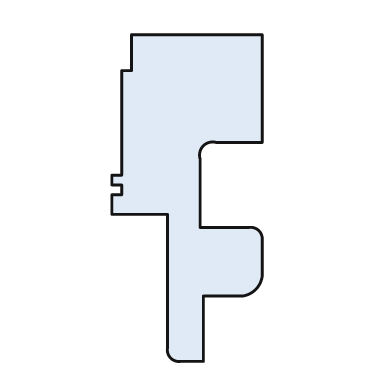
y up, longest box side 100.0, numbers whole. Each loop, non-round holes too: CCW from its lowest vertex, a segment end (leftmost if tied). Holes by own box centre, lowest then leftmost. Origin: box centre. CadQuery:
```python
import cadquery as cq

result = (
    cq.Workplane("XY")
    .moveTo(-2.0, -50.0)
    .lineTo(5.0, -50.0)
    .lineTo(5.0, -30.0)
    .lineTo(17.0, -30.0)
    .threePointArc((21.0, -28.0), (23.0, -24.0))
    .lineTo(23.0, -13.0)
    .threePointArc((22.0, -10.0), (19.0, -9.0))
    .lineTo(4.0, -9.0)
    .lineTo(4.0, 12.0)
    .threePointArc((5.0, 16.0), (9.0, 17.0))
    .lineTo(23.0, 17.0)
    .lineTo(23.0, 50.0)
    .lineTo(-17.0, 50.0)
    .lineTo(-17.0, 39.0)
    .lineTo(-20.0, 39.0)
    .lineTo(-20.0, 7.0)
    .lineTo(-23.0, 7.0)
    .lineTo(-23.0, 4.0)
    .lineTo(-20.0, 4.0)
    .lineTo(-20.0, 1.0)
    .lineTo(-23.0, 1.0)
    .lineTo(-23.0, -5.0)
    .lineTo(-6.0, -5.0)
    .lineTo(-6.0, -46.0)
    .threePointArc((-5.0, -49.0), (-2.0, -50.0))
    .close()
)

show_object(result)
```